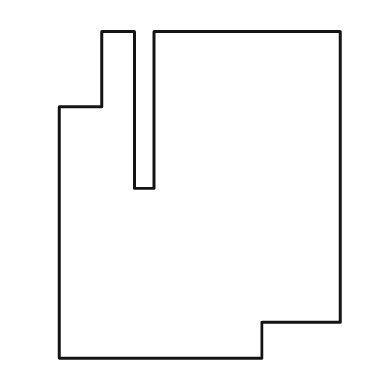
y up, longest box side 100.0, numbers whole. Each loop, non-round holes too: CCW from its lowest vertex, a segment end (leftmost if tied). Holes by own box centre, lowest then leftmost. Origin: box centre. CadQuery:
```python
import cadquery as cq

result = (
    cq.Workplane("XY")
    .moveTo(-43.0, -50.0)
    .lineTo(19.0, -50.0)
    .lineTo(19.0, -39.0)
    .lineTo(43.0, -39.0)
    .lineTo(43.0, 50.0)
    .lineTo(-14.0, 50.0)
    .lineTo(-14.0, 2.0)
    .lineTo(-20.0, 2.0)
    .lineTo(-20.0, 50.0)
    .lineTo(-30.0, 50.0)
    .lineTo(-30.0, 27.0)
    .lineTo(-43.0, 27.0)
    .close()
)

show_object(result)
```